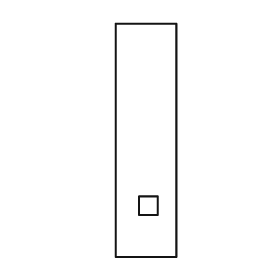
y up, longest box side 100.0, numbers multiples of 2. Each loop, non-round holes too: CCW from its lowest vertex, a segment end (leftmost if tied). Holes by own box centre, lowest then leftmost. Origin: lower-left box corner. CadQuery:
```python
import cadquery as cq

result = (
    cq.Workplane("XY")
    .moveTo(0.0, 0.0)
    .lineTo(26.0, 0.0)
    .lineTo(26.0, 100.0)
    .lineTo(0.0, 100.0)
    .close()
    .moveTo(10.0, 18.0)
    .lineTo(18.0, 18.0)
    .lineTo(18.0, 26.0)
    .lineTo(10.0, 26.0)
    .close()
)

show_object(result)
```